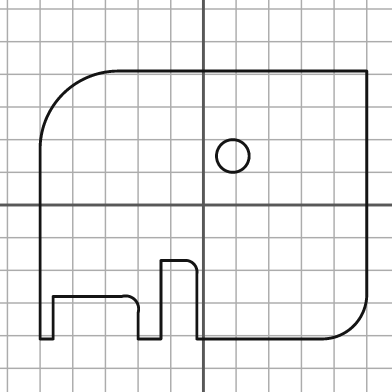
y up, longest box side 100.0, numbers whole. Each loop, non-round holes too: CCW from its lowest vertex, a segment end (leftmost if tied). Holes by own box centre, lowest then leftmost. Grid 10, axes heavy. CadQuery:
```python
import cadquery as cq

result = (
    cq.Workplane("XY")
    .moveTo(-50.0, -41.0)
    .lineTo(-46.0, -41.0)
    .lineTo(-46.0, -28.0)
    .lineTo(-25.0, -28.0)
    .threePointArc((-21.0, -29.0), (-20.0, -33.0))
    .lineTo(-20.0, -41.0)
    .lineTo(-13.0, -41.0)
    .lineTo(-13.0, -17.0)
    .lineTo(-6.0, -17.0)
    .threePointArc((-3.0, -18.0), (-2.0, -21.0))
    .lineTo(-2.0, -41.0)
    .lineTo(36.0, -41.0)
    .threePointArc((46.0, -37.0), (50.0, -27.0))
    .lineTo(50.0, 41.0)
    .lineTo(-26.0, 41.0)
    .threePointArc((-43.0, 34.0), (-50.0, 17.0))
    .close()
    .moveTo(9.0, 15.0)
    .circle(5.0)
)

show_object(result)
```